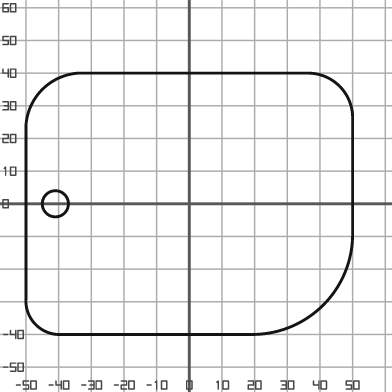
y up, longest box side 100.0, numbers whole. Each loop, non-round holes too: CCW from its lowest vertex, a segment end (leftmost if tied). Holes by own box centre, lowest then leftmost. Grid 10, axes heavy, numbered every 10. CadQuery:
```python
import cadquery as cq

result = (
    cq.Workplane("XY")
    .moveTo(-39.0, -40.0)
    .lineTo(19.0, -40.0)
    .threePointArc((41.0, -31.0), (50.0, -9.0))
    .lineTo(50.0, 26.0)
    .threePointArc((46.0, 36.0), (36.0, 40.0))
    .lineTo(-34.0, 40.0)
    .threePointArc((-45.0, 35.0), (-50.0, 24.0))
    .lineTo(-50.0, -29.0)
    .threePointArc((-47.0, -37.0), (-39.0, -40.0))
    .close()
    .moveTo(-41.0, 0.0)
    .circle(4.0)
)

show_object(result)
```